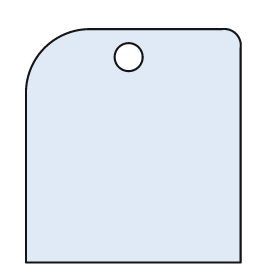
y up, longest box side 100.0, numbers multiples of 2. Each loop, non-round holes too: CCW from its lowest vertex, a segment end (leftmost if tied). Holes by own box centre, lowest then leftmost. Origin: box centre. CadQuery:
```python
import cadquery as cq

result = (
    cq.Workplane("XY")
    .moveTo(-46.0, -50.0)
    .lineTo(46.0, -50.0)
    .lineTo(46.0, 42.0)
    .threePointArc((44.0, 48.0), (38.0, 50.0))
    .lineTo(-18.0, 50.0)
    .threePointArc((-38.0, 42.0), (-46.0, 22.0))
    .close()
    .moveTo(-2.0, 38.0)
    .circle(6.0)
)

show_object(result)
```